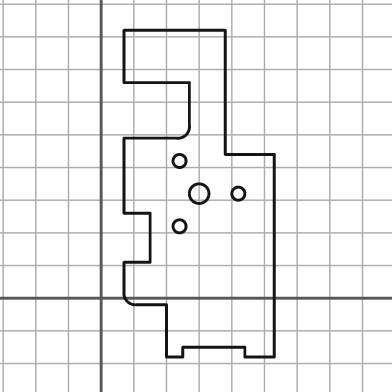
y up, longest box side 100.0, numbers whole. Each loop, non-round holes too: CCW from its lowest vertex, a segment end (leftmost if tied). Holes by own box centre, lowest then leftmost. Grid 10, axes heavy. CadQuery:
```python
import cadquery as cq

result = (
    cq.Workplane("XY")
    .moveTo(20.0, -18.0)
    .lineTo(25.0, -18.0)
    .lineTo(25.0, -15.0)
    .lineTo(44.0, -15.0)
    .lineTo(44.0, -18.0)
    .lineTo(53.0, -18.0)
    .lineTo(53.0, 44.0)
    .lineTo(38.0, 44.0)
    .lineTo(38.0, 82.0)
    .lineTo(7.0, 82.0)
    .lineTo(7.0, 66.0)
    .lineTo(27.0, 66.0)
    .lineTo(27.0, 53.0)
    .threePointArc((26.0, 50.0), (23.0, 49.0))
    .lineTo(7.0, 49.0)
    .lineTo(7.0, 26.0)
    .lineTo(15.0, 26.0)
    .lineTo(15.0, 11.0)
    .lineTo(7.0, 11.0)
    .lineTo(7.0, 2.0)
    .threePointArc((8.0, -1.0), (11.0, -2.0))
    .lineTo(20.0, -2.0)
    .close()
    .moveTo(24.0, 22.0)
    .circle(2.0)
    .moveTo(30.0, 32.0)
    .circle(3.0)
    .moveTo(42.0, 32.0)
    .circle(2.0)
    .moveTo(24.0, 42.0)
    .circle(2.0)
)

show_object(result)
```